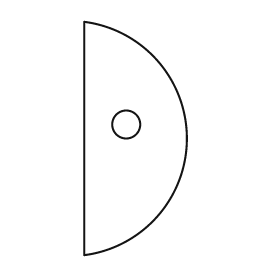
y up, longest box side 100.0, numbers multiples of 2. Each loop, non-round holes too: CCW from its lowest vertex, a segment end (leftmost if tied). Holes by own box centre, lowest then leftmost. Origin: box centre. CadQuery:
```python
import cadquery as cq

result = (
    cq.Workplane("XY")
    .moveTo(-22.0, -50.0)
    .threePointArc((22.0, 0.0), (-22.0, 50.0))
    .close()
    .moveTo(-4.0, 6.0)
    .circle(6.0)
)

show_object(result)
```